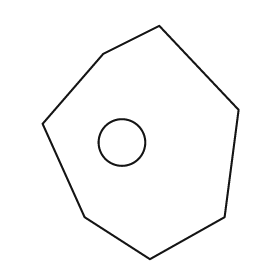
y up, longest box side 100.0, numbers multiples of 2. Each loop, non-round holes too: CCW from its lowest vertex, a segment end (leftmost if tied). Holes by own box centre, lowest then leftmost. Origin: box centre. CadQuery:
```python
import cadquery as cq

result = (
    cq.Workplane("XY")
    .moveTo(4.0, -50.0)
    .lineTo(36.0, -32.0)
    .lineTo(42.0, 14.0)
    .lineTo(8.0, 50.0)
    .lineTo(-16.0, 38.0)
    .lineTo(-42.0, 8.0)
    .lineTo(-24.0, -32.0)
    .close()
    .moveTo(-8.0, 0.0)
    .circle(10.0)
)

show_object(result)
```